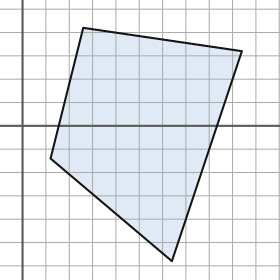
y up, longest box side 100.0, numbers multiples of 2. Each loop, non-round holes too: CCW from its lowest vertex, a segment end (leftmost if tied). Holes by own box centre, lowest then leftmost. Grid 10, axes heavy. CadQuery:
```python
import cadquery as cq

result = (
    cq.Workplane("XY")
    .moveTo(64.0, -58.0)
    .lineTo(94.0, 32.0)
    .lineTo(26.0, 42.0)
    .lineTo(12.0, -14.0)
    .close()
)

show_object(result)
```